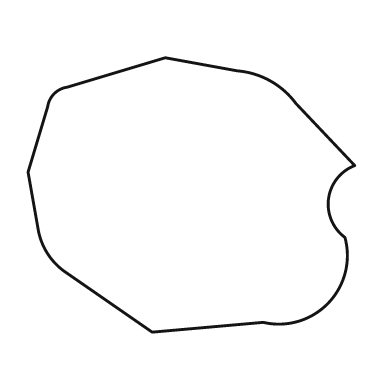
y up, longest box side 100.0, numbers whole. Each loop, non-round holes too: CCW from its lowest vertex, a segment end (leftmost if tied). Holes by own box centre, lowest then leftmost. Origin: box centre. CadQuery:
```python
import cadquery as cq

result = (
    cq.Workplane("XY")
    .moveTo(-12.0, -42.0)
    .lineTo(22.0, -39.0)
    .threePointArc((42.0, -33.0), (47.0, -13.0))
    .threePointArc((42.0, -1.0), (50.0, 9.0))
    .lineTo(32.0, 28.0)
    .threePointArc((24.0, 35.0), (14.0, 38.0))
    .lineTo(-8.0, 42.0)
    .lineTo(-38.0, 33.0)
    .threePointArc((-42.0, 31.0), (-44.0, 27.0))
    .lineTo(-50.0, 7.0)
    .lineTo(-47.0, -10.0)
    .threePointArc((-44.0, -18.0), (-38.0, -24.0))
    .close()
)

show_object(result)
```